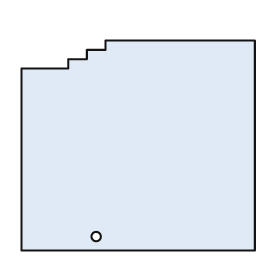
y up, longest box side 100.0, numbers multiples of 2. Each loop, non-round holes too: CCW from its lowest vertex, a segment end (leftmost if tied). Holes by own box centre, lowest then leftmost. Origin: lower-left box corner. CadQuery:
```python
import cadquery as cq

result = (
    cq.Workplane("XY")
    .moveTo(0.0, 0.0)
    .lineTo(100.0, 0.0)
    .lineTo(100.0, 90.0)
    .lineTo(36.0, 90.0)
    .lineTo(36.0, 86.0)
    .lineTo(28.0, 86.0)
    .lineTo(28.0, 82.0)
    .lineTo(20.0, 82.0)
    .lineTo(20.0, 78.0)
    .lineTo(0.0, 78.0)
    .close()
    .moveTo(32.0, 6.0)
    .circle(2.0)
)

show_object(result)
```